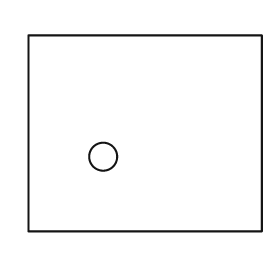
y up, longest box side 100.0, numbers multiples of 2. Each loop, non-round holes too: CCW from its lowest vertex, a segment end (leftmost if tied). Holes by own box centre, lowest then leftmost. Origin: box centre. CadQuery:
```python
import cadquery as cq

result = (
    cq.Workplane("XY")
    .moveTo(-50.0, -42.0)
    .lineTo(50.0, -42.0)
    .lineTo(50.0, 42.0)
    .lineTo(-50.0, 42.0)
    .close()
    .moveTo(-18.0, -10.0)
    .circle(6.0)
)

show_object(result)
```